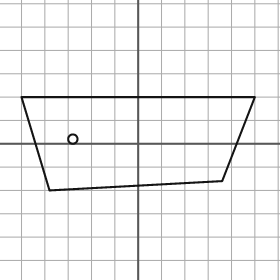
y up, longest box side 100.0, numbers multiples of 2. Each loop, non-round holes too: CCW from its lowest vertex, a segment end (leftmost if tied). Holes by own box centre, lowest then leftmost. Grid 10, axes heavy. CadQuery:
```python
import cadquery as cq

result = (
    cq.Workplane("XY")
    .moveTo(-38.0, -20.0)
    .lineTo(36.0, -16.0)
    .lineTo(50.0, 20.0)
    .lineTo(-50.0, 20.0)
    .close()
    .moveTo(-28.0, 2.0)
    .circle(2.0)
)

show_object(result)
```